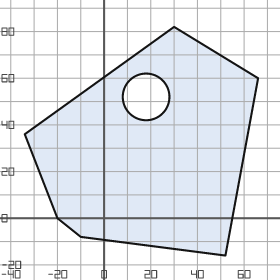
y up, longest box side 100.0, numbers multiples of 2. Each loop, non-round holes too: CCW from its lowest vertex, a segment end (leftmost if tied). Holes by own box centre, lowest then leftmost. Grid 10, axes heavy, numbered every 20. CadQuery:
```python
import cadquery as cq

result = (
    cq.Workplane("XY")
    .moveTo(52.0, -16.0)
    .lineTo(66.0, 60.0)
    .lineTo(30.0, 82.0)
    .lineTo(-34.0, 36.0)
    .lineTo(-20.0, 0.0)
    .lineTo(-10.0, -8.0)
    .close()
    .moveTo(18.0, 52.0)
    .circle(10.0)
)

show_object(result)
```